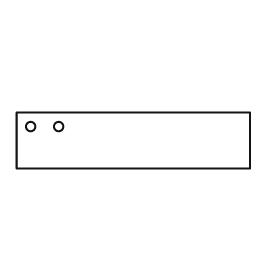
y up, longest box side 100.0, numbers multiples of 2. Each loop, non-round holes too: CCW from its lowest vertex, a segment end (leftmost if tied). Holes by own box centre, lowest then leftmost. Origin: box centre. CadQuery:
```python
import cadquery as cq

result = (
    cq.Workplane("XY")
    .moveTo(-50.0, -12.0)
    .lineTo(50.0, -12.0)
    .lineTo(50.0, 12.0)
    .lineTo(-50.0, 12.0)
    .close()
    .moveTo(-44.0, 6.0)
    .circle(2.0)
    .moveTo(-32.0, 6.0)
    .circle(2.0)
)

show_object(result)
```